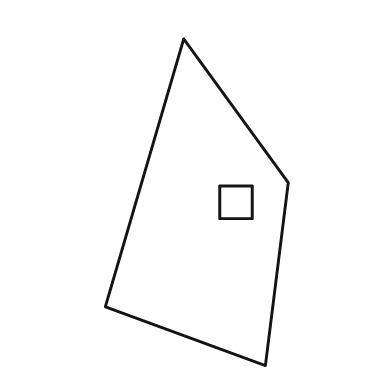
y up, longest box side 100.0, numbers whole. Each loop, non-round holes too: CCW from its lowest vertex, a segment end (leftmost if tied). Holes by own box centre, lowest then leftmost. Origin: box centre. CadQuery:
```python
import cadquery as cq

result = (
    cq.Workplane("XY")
    .moveTo(21.0, -50.0)
    .lineTo(28.0, 6.0)
    .lineTo(-4.0, 50.0)
    .lineTo(-28.0, -32.0)
    .close()
    .moveTo(7.0, -5.0)
    .lineTo(17.0, -5.0)
    .lineTo(17.0, 5.0)
    .lineTo(7.0, 5.0)
    .close()
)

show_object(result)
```